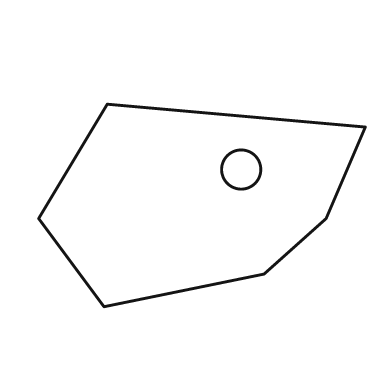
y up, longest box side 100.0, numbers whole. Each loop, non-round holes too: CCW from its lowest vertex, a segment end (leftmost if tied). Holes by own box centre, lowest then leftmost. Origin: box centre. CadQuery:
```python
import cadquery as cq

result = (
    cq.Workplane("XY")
    .moveTo(-30.0, -31.0)
    .lineTo(19.0, -21.0)
    .lineTo(38.0, -4.0)
    .lineTo(50.0, 24.0)
    .lineTo(-29.0, 31.0)
    .lineTo(-50.0, -4.0)
    .close()
    .moveTo(12.0, 11.0)
    .circle(6.0)
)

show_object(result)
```